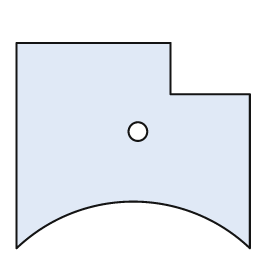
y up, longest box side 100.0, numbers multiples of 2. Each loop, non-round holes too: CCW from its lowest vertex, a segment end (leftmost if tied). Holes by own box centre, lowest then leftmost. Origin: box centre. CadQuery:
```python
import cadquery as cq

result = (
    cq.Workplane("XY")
    .moveTo(-50.0, -44.0)
    .threePointArc((0.0, -24.0), (50.0, -44.0))
    .lineTo(50.0, 22.0)
    .lineTo(16.0, 22.0)
    .lineTo(16.0, 44.0)
    .lineTo(-50.0, 44.0)
    .close()
    .moveTo(2.0, 6.0)
    .circle(4.0)
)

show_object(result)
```